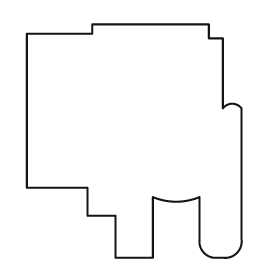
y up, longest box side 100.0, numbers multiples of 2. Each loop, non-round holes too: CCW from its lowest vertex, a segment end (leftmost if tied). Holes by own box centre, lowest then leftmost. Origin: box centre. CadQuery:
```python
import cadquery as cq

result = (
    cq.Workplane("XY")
    .moveTo(-8.0, -50.0)
    .lineTo(8.0, -50.0)
    .lineTo(8.0, -24.0)
    .threePointArc((18.0, -26.0), (28.0, -24.0))
    .lineTo(28.0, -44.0)
    .threePointArc((30.0, -48.0), (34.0, -50.0))
    .lineTo(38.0, -50.0)
    .threePointArc((44.0, -48.0), (46.0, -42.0))
    .lineTo(46.0, 14.0)
    .threePointArc((42.0, 16.0), (38.0, 14.0))
    .lineTo(38.0, 44.0)
    .lineTo(32.0, 44.0)
    .lineTo(32.0, 50.0)
    .lineTo(-18.0, 50.0)
    .lineTo(-18.0, 46.0)
    .lineTo(-46.0, 46.0)
    .lineTo(-46.0, -20.0)
    .lineTo(-20.0, -20.0)
    .lineTo(-20.0, -32.0)
    .lineTo(-8.0, -32.0)
    .close()
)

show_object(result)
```